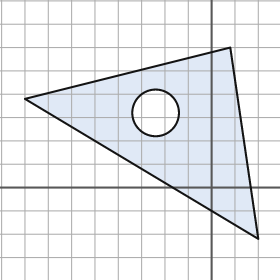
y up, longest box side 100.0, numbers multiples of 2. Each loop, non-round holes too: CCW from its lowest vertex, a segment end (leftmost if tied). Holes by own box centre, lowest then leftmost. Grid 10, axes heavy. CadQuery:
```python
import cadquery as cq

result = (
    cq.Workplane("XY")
    .moveTo(20.0, -22.0)
    .lineTo(8.0, 60.0)
    .lineTo(-80.0, 38.0)
    .close()
    .moveTo(-24.0, 32.0)
    .circle(10.0)
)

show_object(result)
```